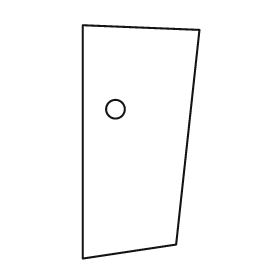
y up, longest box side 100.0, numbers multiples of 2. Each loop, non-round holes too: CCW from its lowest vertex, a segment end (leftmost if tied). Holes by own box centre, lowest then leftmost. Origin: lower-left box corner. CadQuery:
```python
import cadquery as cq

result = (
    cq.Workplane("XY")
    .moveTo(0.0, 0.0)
    .lineTo(40.0, 6.0)
    .lineTo(50.0, 98.0)
    .lineTo(0.0, 100.0)
    .close()
    .moveTo(14.0, 64.0)
    .circle(4.0)
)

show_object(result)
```